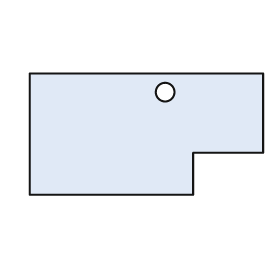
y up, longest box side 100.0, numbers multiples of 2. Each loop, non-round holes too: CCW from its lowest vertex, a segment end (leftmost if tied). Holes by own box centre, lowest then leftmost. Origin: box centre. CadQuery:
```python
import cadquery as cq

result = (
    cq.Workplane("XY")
    .moveTo(-50.0, -26.0)
    .lineTo(20.0, -26.0)
    .lineTo(20.0, -8.0)
    .lineTo(50.0, -8.0)
    .lineTo(50.0, 26.0)
    .lineTo(-50.0, 26.0)
    .close()
    .moveTo(8.0, 18.0)
    .circle(4.0)
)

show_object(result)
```